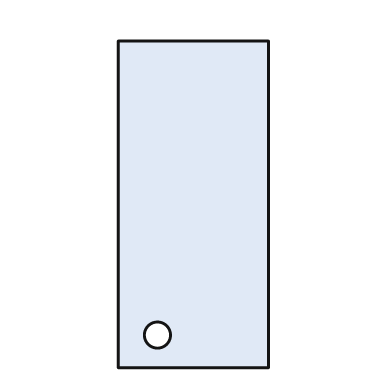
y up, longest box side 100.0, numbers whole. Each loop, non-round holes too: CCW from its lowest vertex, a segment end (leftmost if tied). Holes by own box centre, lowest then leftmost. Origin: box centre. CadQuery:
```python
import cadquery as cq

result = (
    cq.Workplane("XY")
    .moveTo(-23.0, -50.0)
    .lineTo(23.0, -50.0)
    .lineTo(23.0, 50.0)
    .lineTo(-23.0, 50.0)
    .close()
    .moveTo(-11.0, -40.0)
    .circle(4.0)
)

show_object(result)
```